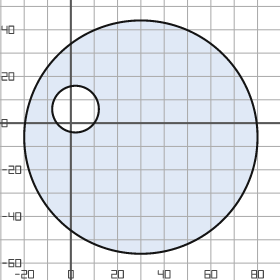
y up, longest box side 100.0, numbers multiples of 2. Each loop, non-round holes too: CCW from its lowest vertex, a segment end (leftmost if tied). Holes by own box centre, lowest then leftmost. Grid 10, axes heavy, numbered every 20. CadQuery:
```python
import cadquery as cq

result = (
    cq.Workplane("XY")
    .moveTo(30.0, -6.0)
    .circle(50.0)
    .moveTo(2.0, 6.0)
    .circle(10.0)
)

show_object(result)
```